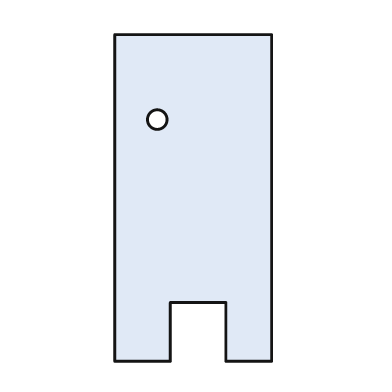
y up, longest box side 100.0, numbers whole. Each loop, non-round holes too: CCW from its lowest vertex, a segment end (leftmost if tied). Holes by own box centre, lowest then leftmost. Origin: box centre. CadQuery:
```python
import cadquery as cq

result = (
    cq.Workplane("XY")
    .moveTo(-24.0, -50.0)
    .lineTo(-7.0, -50.0)
    .lineTo(-7.0, -32.0)
    .lineTo(10.0, -32.0)
    .lineTo(10.0, -50.0)
    .lineTo(24.0, -50.0)
    .lineTo(24.0, 50.0)
    .lineTo(-24.0, 50.0)
    .close()
    .moveTo(-11.0, 24.0)
    .circle(3.0)
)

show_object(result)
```